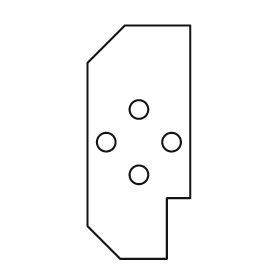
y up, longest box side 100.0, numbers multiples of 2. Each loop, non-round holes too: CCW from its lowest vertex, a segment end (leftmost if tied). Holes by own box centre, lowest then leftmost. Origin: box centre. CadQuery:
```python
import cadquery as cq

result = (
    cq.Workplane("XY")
    .moveTo(-8.0, -50.0)
    .lineTo(12.0, -50.0)
    .lineTo(12.0, -24.0)
    .lineTo(22.0, -24.0)
    .lineTo(22.0, 50.0)
    .lineTo(-6.0, 50.0)
    .lineTo(-22.0, 34.0)
    .lineTo(-22.0, -36.0)
    .close()
    .moveTo(0.0, -14.0)
    .circle(4.0)
    .moveTo(-14.0, 0.0)
    .circle(4.0)
    .moveTo(14.0, 0.0)
    .circle(4.0)
    .moveTo(0.0, 14.0)
    .circle(4.0)
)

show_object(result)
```